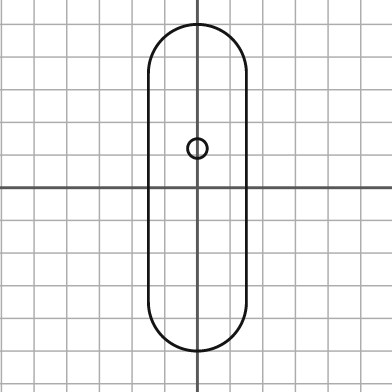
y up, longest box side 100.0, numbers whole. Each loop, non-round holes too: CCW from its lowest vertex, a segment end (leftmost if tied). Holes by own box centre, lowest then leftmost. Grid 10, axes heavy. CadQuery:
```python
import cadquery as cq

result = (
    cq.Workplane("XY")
    .moveTo(-15.0, -35.0)
    .threePointArc((0.0, -50.0), (15.0, -35.0))
    .lineTo(15.0, 35.0)
    .threePointArc((0.0, 50.0), (-15.0, 35.0))
    .close()
    .moveTo(0.0, 12.0)
    .circle(3.0)
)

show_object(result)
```